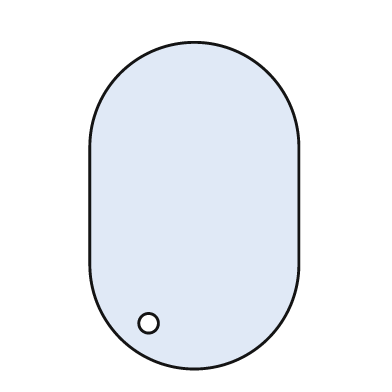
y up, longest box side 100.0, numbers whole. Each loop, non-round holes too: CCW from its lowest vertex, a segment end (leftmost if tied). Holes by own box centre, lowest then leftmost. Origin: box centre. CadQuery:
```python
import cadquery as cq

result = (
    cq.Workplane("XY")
    .moveTo(-32.0, -18.0)
    .threePointArc((0.0, -50.0), (32.0, -18.0))
    .lineTo(32.0, 18.0)
    .threePointArc((0.0, 50.0), (-32.0, 18.0))
    .close()
    .moveTo(-14.0, -36.0)
    .circle(3.0)
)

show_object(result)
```